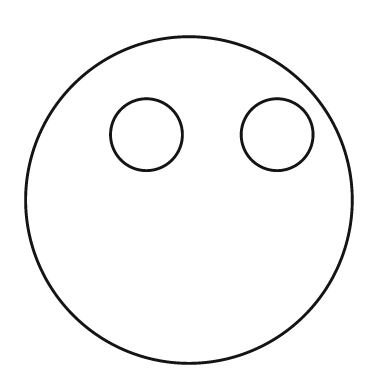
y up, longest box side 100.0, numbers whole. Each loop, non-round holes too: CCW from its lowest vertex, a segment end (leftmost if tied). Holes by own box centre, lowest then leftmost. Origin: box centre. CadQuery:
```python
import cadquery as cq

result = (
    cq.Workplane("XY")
    .moveTo(0.0, 0.0)
    .circle(50.0)
    .moveTo(-13.0, 20.0)
    .circle(11.0)
    .moveTo(27.0, 20.0)
    .circle(11.0)
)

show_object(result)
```